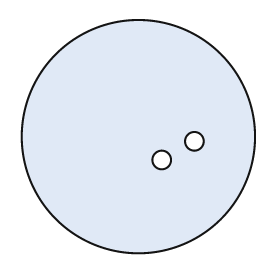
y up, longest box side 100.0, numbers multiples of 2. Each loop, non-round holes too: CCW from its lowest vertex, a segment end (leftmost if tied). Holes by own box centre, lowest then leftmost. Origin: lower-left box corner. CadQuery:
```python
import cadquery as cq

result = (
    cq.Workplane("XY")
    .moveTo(50.0, 50.0)
    .circle(50.0)
    .moveTo(60.0, 40.0)
    .circle(4.0)
    .moveTo(74.0, 48.0)
    .circle(4.0)
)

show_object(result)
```